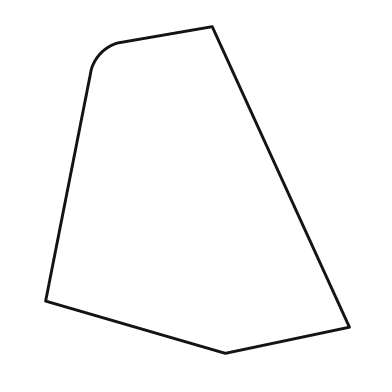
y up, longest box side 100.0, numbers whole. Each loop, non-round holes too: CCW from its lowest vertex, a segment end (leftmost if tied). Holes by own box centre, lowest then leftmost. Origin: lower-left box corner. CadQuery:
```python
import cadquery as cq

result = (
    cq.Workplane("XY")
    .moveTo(55.0, 0.0)
    .lineTo(93.0, 8.0)
    .lineTo(51.0, 100.0)
    .lineTo(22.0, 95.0)
    .threePointArc((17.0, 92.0), (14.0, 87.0))
    .lineTo(0.0, 16.0)
    .close()
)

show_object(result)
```